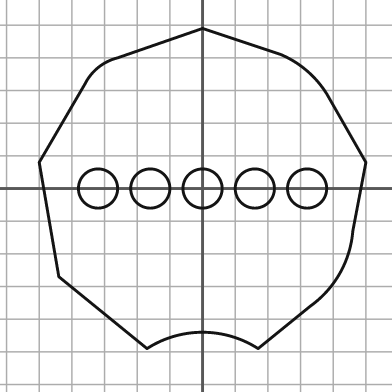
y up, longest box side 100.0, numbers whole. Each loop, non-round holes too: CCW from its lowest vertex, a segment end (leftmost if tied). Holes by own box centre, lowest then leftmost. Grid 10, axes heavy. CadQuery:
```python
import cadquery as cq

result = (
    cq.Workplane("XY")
    .moveTo(-17.0, -49.0)
    .threePointArc((0.0, -44.0), (17.0, -49.0))
    .lineTo(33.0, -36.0)
    .threePointArc((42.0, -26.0), (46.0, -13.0))
    .lineTo(50.0, 8.0)
    .lineTo(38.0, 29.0)
    .threePointArc((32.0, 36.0), (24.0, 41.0))
    .lineTo(0.0, 49.0)
    .lineTo(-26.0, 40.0)
    .threePointArc((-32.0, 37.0), (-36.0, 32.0))
    .lineTo(-50.0, 8.0)
    .lineTo(-44.0, -27.0)
    .close()
    .moveTo(-32.0, 0.0)
    .circle(6.0)
    .moveTo(-16.0, 0.0)
    .circle(6.0)
    .moveTo(0.0, 0.0)
    .circle(6.0)
    .moveTo(16.0, 0.0)
    .circle(6.0)
    .moveTo(32.0, 0.0)
    .circle(6.0)
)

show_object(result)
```